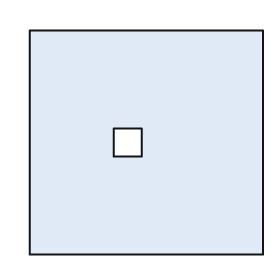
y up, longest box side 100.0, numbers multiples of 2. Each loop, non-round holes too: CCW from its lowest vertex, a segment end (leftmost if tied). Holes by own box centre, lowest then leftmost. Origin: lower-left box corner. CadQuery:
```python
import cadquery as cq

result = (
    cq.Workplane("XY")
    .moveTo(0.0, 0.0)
    .lineTo(100.0, 0.0)
    .lineTo(100.0, 96.0)
    .lineTo(0.0, 96.0)
    .close()
    .moveTo(36.0, 42.0)
    .lineTo(48.0, 42.0)
    .lineTo(48.0, 54.0)
    .lineTo(36.0, 54.0)
    .close()
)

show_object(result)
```